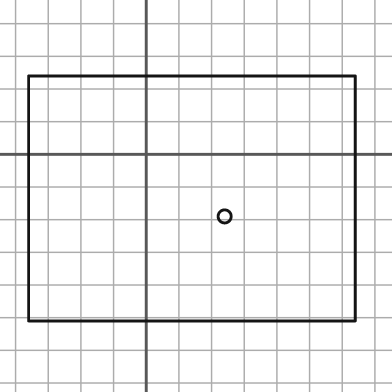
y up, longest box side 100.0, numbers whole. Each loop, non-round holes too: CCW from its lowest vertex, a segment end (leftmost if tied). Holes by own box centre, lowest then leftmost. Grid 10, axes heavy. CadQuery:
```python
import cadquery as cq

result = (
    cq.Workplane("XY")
    .moveTo(-36.0, -51.0)
    .lineTo(64.0, -51.0)
    .lineTo(64.0, 24.0)
    .lineTo(-36.0, 24.0)
    .close()
    .moveTo(24.0, -19.0)
    .circle(2.0)
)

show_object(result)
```